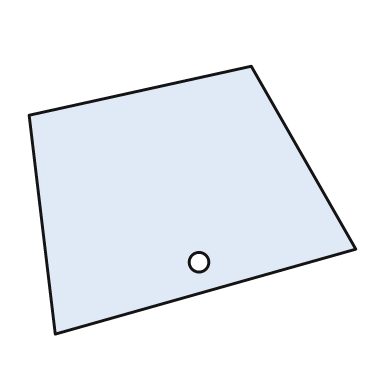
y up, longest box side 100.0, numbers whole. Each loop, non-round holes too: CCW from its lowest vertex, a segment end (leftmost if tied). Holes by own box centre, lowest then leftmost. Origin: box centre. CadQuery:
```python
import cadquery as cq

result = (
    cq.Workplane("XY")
    .moveTo(-42.0, -41.0)
    .lineTo(50.0, -15.0)
    .lineTo(18.0, 41.0)
    .lineTo(-50.0, 26.0)
    .close()
    .moveTo(2.0, -19.0)
    .circle(3.0)
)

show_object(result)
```